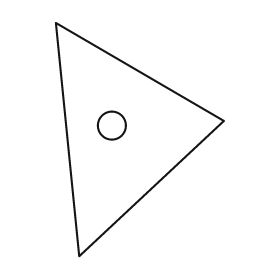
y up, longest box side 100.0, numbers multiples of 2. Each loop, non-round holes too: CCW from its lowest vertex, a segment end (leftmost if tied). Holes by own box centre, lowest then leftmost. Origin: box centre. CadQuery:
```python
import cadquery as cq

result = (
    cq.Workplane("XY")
    .moveTo(-26.0, -50.0)
    .lineTo(36.0, 8.0)
    .lineTo(-36.0, 50.0)
    .close()
    .moveTo(-12.0, 6.0)
    .circle(6.0)
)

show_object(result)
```